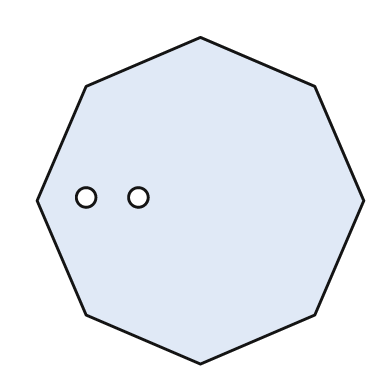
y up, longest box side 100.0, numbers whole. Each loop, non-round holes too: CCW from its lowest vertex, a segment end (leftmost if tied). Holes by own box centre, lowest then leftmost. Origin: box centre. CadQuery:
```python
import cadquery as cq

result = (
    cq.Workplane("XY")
    .moveTo(0.0, -50.0)
    .lineTo(35.0, -35.0)
    .lineTo(50.0, 0.0)
    .lineTo(35.0, 35.0)
    .lineTo(0.0, 50.0)
    .lineTo(-35.0, 35.0)
    .lineTo(-50.0, 0.0)
    .lineTo(-35.0, -35.0)
    .close()
    .moveTo(-35.0, 1.0)
    .circle(3.0)
    .moveTo(-19.0, 1.0)
    .circle(3.0)
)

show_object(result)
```